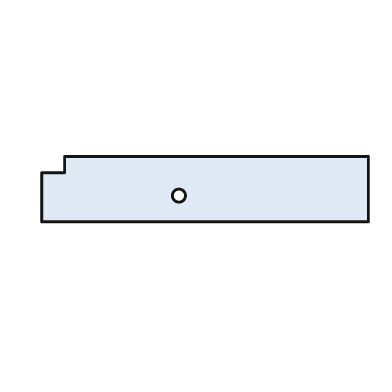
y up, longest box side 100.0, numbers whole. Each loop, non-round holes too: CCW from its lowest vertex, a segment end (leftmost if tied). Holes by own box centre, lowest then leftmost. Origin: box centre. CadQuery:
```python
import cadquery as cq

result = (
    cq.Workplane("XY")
    .moveTo(-50.0, -10.0)
    .lineTo(50.0, -10.0)
    .lineTo(50.0, 10.0)
    .lineTo(-43.0, 10.0)
    .lineTo(-43.0, 5.0)
    .lineTo(-50.0, 5.0)
    .close()
    .moveTo(-8.0, -2.0)
    .circle(2.0)
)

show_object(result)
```